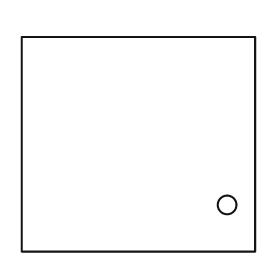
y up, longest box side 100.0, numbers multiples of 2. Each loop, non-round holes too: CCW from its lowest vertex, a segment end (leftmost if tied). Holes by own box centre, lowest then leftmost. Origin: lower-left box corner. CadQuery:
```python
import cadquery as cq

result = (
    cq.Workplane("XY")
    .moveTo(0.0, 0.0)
    .lineTo(100.0, 0.0)
    .lineTo(100.0, 92.0)
    .lineTo(0.0, 92.0)
    .close()
    .moveTo(88.0, 20.0)
    .circle(4.0)
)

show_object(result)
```